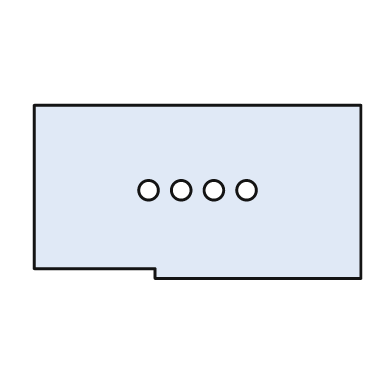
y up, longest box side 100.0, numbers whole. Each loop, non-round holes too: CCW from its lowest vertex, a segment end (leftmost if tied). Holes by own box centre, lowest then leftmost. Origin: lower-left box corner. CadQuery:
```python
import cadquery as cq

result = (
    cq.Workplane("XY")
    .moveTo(37.0, 0.0)
    .lineTo(100.0, 0.0)
    .lineTo(100.0, 53.0)
    .lineTo(0.0, 53.0)
    .lineTo(0.0, 3.0)
    .lineTo(37.0, 3.0)
    .close()
    .moveTo(35.0, 27.0)
    .circle(3.0)
    .moveTo(45.0, 27.0)
    .circle(3.0)
    .moveTo(55.0, 27.0)
    .circle(3.0)
    .moveTo(65.0, 27.0)
    .circle(3.0)
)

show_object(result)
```